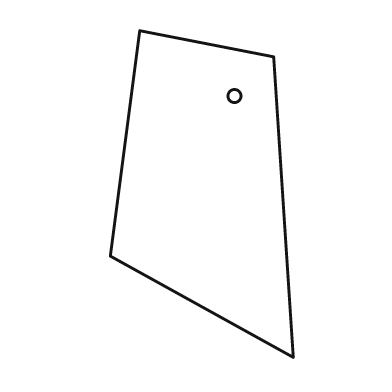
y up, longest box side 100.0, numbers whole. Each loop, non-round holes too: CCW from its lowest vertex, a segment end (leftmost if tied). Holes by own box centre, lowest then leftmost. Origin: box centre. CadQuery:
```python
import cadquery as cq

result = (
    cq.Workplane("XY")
    .moveTo(28.0, -50.0)
    .lineTo(22.0, 42.0)
    .lineTo(-19.0, 50.0)
    .lineTo(-28.0, -19.0)
    .close()
    .moveTo(10.0, 30.0)
    .circle(2.0)
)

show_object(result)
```